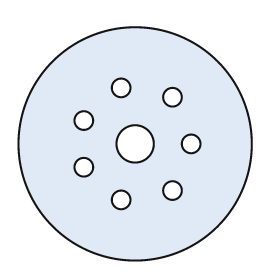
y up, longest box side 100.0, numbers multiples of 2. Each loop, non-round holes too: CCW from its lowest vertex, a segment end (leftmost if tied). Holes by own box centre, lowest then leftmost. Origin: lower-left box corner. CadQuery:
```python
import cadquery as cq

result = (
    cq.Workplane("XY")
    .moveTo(50.0, 50.0)
    .circle(50.0)
    .moveTo(44.0, 26.0)
    .circle(4.0)
    .moveTo(66.0, 30.0)
    .circle(4.0)
    .moveTo(28.0, 40.0)
    .circle(4.0)
    .moveTo(50.0, 50.0)
    .circle(8.0)
    .moveTo(74.0, 50.0)
    .circle(4.0)
    .moveTo(28.0, 60.0)
    .circle(4.0)
    .moveTo(66.0, 70.0)
    .circle(4.0)
    .moveTo(44.0, 74.0)
    .circle(4.0)
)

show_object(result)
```